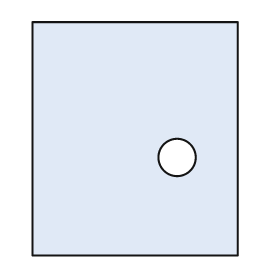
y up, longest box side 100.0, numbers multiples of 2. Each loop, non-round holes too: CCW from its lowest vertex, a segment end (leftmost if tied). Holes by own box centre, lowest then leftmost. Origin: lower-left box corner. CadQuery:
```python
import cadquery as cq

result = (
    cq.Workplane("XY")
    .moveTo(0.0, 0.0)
    .lineTo(88.0, 0.0)
    .lineTo(88.0, 100.0)
    .lineTo(0.0, 100.0)
    .close()
    .moveTo(62.0, 42.0)
    .circle(8.0)
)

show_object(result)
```